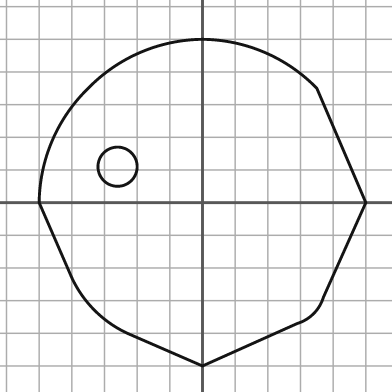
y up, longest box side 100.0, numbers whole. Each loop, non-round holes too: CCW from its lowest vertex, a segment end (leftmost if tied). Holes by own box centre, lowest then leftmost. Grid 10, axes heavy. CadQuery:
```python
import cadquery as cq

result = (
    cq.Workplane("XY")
    .moveTo(0.0, -50.0)
    .lineTo(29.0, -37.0)
    .threePointArc((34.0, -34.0), (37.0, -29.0))
    .lineTo(50.0, 0.0)
    .lineTo(35.0, 35.0)
    .threePointArc((19.0, 46.0), (0.0, 50.0))
    .threePointArc((-19.0, 46.0), (-35.0, 35.0))
    .threePointArc((-46.0, 19.0), (-50.0, 0.0))
    .lineTo(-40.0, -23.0)
    .threePointArc((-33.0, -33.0), (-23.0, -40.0))
    .close()
    .moveTo(-26.0, 11.0)
    .circle(6.0)
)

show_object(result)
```